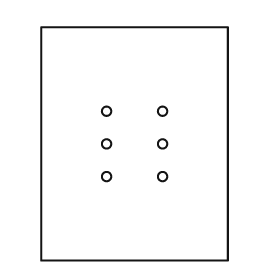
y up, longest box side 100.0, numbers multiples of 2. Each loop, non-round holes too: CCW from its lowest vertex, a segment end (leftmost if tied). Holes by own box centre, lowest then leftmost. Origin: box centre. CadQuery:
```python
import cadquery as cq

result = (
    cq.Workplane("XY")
    .moveTo(-40.0, -50.0)
    .lineTo(40.0, -50.0)
    .lineTo(40.0, 50.0)
    .lineTo(-40.0, 50.0)
    .close()
    .moveTo(-12.0, -14.0)
    .circle(2.0)
    .moveTo(12.0, -14.0)
    .circle(2.0)
    .moveTo(-12.0, 0.0)
    .circle(2.0)
    .moveTo(12.0, 0.0)
    .circle(2.0)
    .moveTo(-12.0, 14.0)
    .circle(2.0)
    .moveTo(12.0, 14.0)
    .circle(2.0)
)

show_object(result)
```